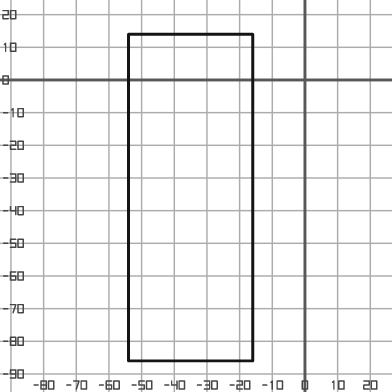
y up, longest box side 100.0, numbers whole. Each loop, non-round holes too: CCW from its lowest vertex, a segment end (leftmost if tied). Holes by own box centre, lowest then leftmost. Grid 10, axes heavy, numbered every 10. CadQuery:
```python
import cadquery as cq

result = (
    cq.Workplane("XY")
    .moveTo(-54.0, -86.0)
    .lineTo(-16.0, -86.0)
    .lineTo(-16.0, 14.0)
    .lineTo(-54.0, 14.0)
    .close()
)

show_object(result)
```